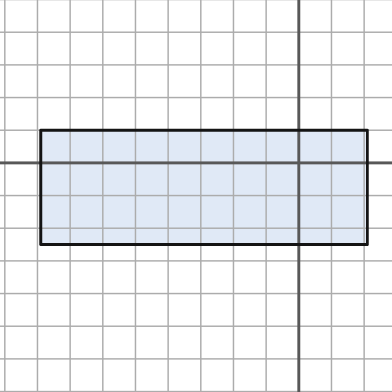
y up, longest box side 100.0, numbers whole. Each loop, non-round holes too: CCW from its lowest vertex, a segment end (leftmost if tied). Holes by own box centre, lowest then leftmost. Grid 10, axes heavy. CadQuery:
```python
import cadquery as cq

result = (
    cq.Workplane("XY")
    .moveTo(-79.0, -25.0)
    .lineTo(21.0, -25.0)
    .lineTo(21.0, 10.0)
    .lineTo(-79.0, 10.0)
    .close()
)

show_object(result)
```